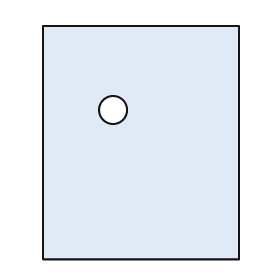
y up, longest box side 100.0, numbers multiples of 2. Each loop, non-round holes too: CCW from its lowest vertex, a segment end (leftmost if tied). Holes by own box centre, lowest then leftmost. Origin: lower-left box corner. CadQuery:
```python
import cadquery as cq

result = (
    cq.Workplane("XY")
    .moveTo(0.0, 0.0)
    .lineTo(84.0, 0.0)
    .lineTo(84.0, 100.0)
    .lineTo(0.0, 100.0)
    .close()
    .moveTo(30.0, 64.0)
    .circle(6.0)
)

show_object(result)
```